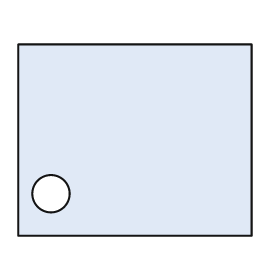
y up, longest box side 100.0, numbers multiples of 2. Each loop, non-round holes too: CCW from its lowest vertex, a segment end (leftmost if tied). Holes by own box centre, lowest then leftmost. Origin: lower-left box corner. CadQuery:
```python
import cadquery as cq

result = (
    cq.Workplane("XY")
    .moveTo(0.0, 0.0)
    .lineTo(100.0, 0.0)
    .lineTo(100.0, 82.0)
    .lineTo(0.0, 82.0)
    .close()
    .moveTo(14.0, 18.0)
    .circle(8.0)
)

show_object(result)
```